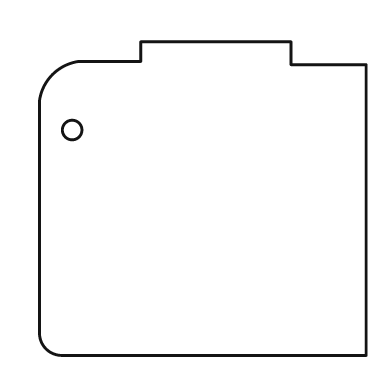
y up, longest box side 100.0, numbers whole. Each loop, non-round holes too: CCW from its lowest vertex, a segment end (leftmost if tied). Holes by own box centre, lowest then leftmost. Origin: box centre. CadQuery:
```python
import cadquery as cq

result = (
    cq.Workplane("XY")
    .moveTo(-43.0, -48.0)
    .lineTo(50.0, -48.0)
    .lineTo(50.0, 41.0)
    .lineTo(27.0, 41.0)
    .lineTo(27.0, 48.0)
    .lineTo(-19.0, 48.0)
    .lineTo(-19.0, 42.0)
    .lineTo(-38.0, 42.0)
    .threePointArc((-46.0, 38.0), (-50.0, 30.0))
    .lineTo(-50.0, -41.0)
    .threePointArc((-48.0, -46.0), (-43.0, -48.0))
    .close()
    .moveTo(-40.0, 21.0)
    .circle(3.0)
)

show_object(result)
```